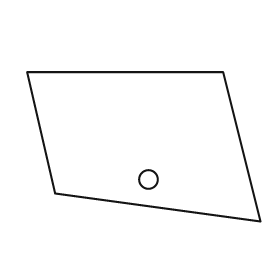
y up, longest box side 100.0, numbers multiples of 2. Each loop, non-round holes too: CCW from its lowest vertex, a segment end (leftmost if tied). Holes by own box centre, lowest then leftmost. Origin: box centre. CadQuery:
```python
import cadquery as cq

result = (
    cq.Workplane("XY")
    .moveTo(50.0, -32.0)
    .lineTo(34.0, 32.0)
    .lineTo(-50.0, 32.0)
    .lineTo(-38.0, -20.0)
    .close()
    .moveTo(2.0, -14.0)
    .circle(4.0)
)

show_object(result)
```